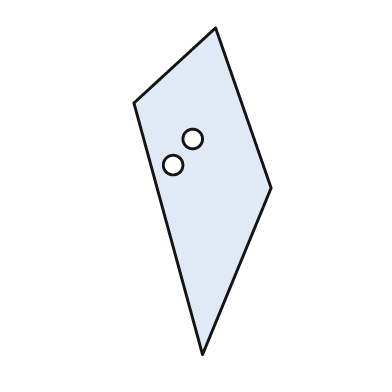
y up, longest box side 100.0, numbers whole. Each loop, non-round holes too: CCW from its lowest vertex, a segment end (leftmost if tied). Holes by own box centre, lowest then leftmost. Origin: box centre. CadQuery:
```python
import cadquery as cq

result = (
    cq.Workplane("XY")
    .moveTo(0.0, -50.0)
    .lineTo(21.0, 1.0)
    .lineTo(4.0, 50.0)
    .lineTo(-21.0, 27.0)
    .close()
    .moveTo(-9.0, 8.0)
    .circle(3.0)
    .moveTo(-3.0, 16.0)
    .circle(3.0)
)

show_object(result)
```